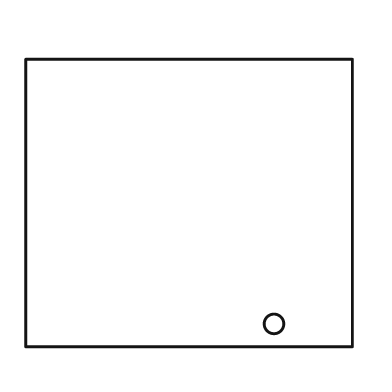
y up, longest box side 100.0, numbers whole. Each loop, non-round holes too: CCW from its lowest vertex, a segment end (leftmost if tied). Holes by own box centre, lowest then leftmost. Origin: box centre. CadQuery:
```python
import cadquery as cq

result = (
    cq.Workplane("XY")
    .moveTo(-50.0, -44.0)
    .lineTo(50.0, -44.0)
    .lineTo(50.0, 44.0)
    .lineTo(-50.0, 44.0)
    .close()
    .moveTo(26.0, -37.0)
    .circle(3.0)
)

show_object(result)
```